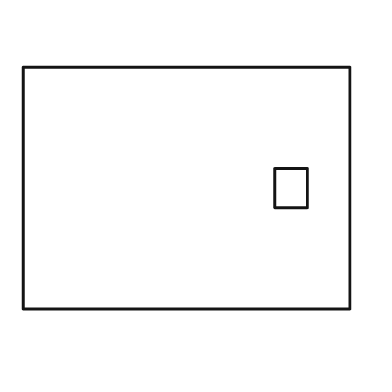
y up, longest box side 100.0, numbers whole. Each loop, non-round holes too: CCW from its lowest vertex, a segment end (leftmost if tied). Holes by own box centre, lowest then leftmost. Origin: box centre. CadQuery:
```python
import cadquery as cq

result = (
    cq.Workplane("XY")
    .moveTo(-50.0, -37.0)
    .lineTo(50.0, -37.0)
    .lineTo(50.0, 37.0)
    .lineTo(-50.0, 37.0)
    .close()
    .moveTo(27.0, -6.0)
    .lineTo(37.0, -6.0)
    .lineTo(37.0, 6.0)
    .lineTo(27.0, 6.0)
    .close()
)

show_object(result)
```